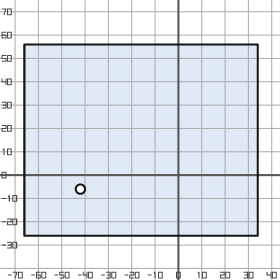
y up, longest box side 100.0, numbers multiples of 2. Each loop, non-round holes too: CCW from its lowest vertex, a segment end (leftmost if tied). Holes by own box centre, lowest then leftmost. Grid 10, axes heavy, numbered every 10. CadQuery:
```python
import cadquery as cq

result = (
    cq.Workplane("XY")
    .moveTo(-66.0, -26.0)
    .lineTo(34.0, -26.0)
    .lineTo(34.0, 56.0)
    .lineTo(-66.0, 56.0)
    .close()
    .moveTo(-42.0, -6.0)
    .circle(2.0)
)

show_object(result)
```